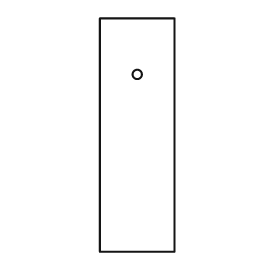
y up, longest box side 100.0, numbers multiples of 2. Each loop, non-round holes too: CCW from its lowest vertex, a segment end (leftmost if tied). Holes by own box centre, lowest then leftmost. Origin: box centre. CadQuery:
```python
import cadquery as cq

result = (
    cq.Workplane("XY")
    .moveTo(-16.0, -50.0)
    .lineTo(16.0, -50.0)
    .lineTo(16.0, 50.0)
    .lineTo(-16.0, 50.0)
    .close()
    .moveTo(0.0, 26.0)
    .circle(2.0)
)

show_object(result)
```